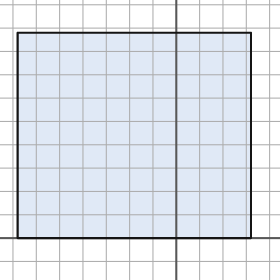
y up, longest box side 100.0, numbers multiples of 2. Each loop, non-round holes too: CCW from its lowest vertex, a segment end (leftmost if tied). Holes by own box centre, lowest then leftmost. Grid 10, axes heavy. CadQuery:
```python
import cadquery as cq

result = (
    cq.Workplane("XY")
    .moveTo(-68.0, 0.0)
    .lineTo(32.0, 0.0)
    .lineTo(32.0, 88.0)
    .lineTo(-68.0, 88.0)
    .close()
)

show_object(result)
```